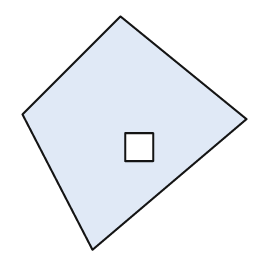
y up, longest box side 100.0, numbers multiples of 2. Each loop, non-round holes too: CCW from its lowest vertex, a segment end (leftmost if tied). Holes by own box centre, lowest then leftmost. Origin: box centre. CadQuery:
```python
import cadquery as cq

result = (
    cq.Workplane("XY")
    .moveTo(-18.0, -50.0)
    .lineTo(48.0, 6.0)
    .lineTo(-6.0, 50.0)
    .lineTo(-48.0, 8.0)
    .close()
    .moveTo(-4.0, -12.0)
    .lineTo(8.0, -12.0)
    .lineTo(8.0, 0.0)
    .lineTo(-4.0, 0.0)
    .close()
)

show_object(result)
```